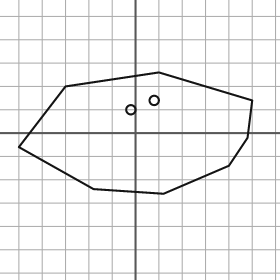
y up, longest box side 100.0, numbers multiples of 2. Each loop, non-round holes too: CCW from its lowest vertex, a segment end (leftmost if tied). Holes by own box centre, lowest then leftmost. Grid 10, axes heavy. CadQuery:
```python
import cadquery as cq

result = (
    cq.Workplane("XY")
    .moveTo(12.0, -26.0)
    .lineTo(40.0, -14.0)
    .lineTo(48.0, -2.0)
    .lineTo(50.0, 14.0)
    .lineTo(10.0, 26.0)
    .lineTo(-30.0, 20.0)
    .lineTo(-50.0, -6.0)
    .lineTo(-18.0, -24.0)
    .close()
    .moveTo(-2.0, 10.0)
    .circle(2.0)
    .moveTo(8.0, 14.0)
    .circle(2.0)
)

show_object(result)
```